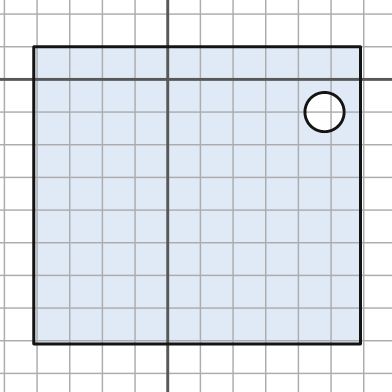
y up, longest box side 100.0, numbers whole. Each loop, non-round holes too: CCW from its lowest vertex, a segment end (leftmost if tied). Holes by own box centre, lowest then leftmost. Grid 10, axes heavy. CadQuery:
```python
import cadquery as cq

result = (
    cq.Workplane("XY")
    .moveTo(-41.0, -81.0)
    .lineTo(59.0, -81.0)
    .lineTo(59.0, 10.0)
    .lineTo(-41.0, 10.0)
    .close()
    .moveTo(48.0, -10.0)
    .circle(6.0)
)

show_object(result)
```